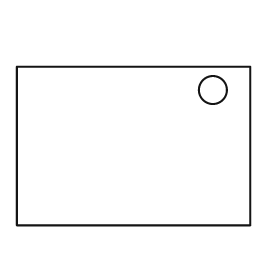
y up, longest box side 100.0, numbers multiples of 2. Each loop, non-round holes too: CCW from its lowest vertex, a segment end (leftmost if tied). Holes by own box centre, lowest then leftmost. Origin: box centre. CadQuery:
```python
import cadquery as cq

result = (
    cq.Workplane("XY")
    .moveTo(-50.0, -34.0)
    .lineTo(50.0, -34.0)
    .lineTo(50.0, 34.0)
    .lineTo(-50.0, 34.0)
    .close()
    .moveTo(34.0, 24.0)
    .circle(6.0)
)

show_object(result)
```